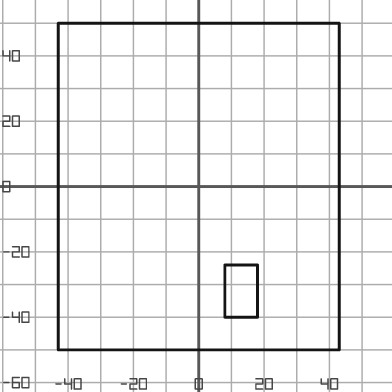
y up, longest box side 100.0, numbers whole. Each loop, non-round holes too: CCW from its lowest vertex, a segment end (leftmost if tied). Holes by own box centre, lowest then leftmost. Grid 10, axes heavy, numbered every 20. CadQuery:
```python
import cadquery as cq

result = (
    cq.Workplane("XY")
    .moveTo(-43.0, -50.0)
    .lineTo(43.0, -50.0)
    .lineTo(43.0, 50.0)
    .lineTo(-43.0, 50.0)
    .close()
    .moveTo(8.0, -40.0)
    .lineTo(18.0, -40.0)
    .lineTo(18.0, -24.0)
    .lineTo(8.0, -24.0)
    .close()
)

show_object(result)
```